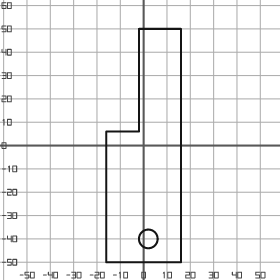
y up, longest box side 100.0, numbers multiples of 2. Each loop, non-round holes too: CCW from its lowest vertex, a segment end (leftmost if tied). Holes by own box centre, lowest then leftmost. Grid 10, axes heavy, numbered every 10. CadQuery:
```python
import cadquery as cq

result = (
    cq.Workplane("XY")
    .moveTo(-16.0, -50.0)
    .lineTo(16.0, -50.0)
    .lineTo(16.0, 50.0)
    .lineTo(-2.0, 50.0)
    .lineTo(-2.0, 6.0)
    .lineTo(-16.0, 6.0)
    .close()
    .moveTo(2.0, -40.0)
    .circle(4.0)
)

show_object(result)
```